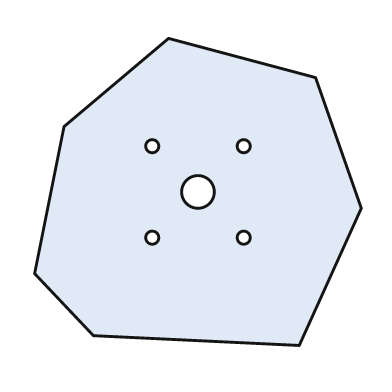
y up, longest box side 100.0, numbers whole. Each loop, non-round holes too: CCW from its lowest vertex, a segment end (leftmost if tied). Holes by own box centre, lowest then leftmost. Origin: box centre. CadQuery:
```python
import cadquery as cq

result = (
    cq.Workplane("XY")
    .moveTo(31.0, -47.0)
    .lineTo(50.0, -5.0)
    .lineTo(36.0, 35.0)
    .lineTo(-9.0, 47.0)
    .lineTo(-41.0, 20.0)
    .lineTo(-50.0, -25.0)
    .lineTo(-32.0, -44.0)
    .close()
    .moveTo(-14.0, -14.0)
    .circle(2.0)
    .moveTo(14.0, -14.0)
    .circle(2.0)
    .moveTo(0.0, 0.0)
    .circle(5.0)
    .moveTo(-14.0, 14.0)
    .circle(2.0)
    .moveTo(14.0, 14.0)
    .circle(2.0)
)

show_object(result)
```